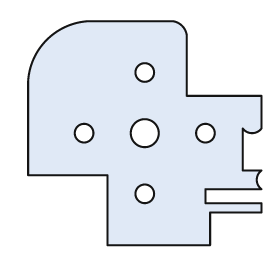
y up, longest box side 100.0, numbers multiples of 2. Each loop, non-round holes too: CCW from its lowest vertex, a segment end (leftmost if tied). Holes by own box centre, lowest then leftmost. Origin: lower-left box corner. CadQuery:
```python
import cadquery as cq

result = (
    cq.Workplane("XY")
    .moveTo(34.0, 0.0)
    .lineTo(78.0, 0.0)
    .lineTo(78.0, 14.0)
    .lineTo(100.0, 14.0)
    .lineTo(100.0, 18.0)
    .lineTo(76.0, 18.0)
    .lineTo(76.0, 24.0)
    .lineTo(100.0, 24.0)
    .threePointArc((98.0, 28.0), (100.0, 32.0))
    .lineTo(92.0, 32.0)
    .lineTo(92.0, 50.0)
    .threePointArc((96.0, 48.0), (100.0, 50.0))
    .lineTo(100.0, 64.0)
    .lineTo(68.0, 64.0)
    .lineTo(68.0, 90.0)
    .threePointArc((66.0, 94.0), (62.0, 96.0))
    .lineTo(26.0, 96.0)
    .threePointArc((8.0, 88.0), (0.0, 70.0))
    .lineTo(0.0, 30.0)
    .lineTo(34.0, 30.0)
    .close()
    .moveTo(50.0, 22.0)
    .circle(4.0)
    .moveTo(24.0, 48.0)
    .circle(4.0)
    .moveTo(50.0, 48.0)
    .circle(6.0)
    .moveTo(76.0, 48.0)
    .circle(4.0)
    .moveTo(50.0, 74.0)
    .circle(4.0)
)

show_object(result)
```